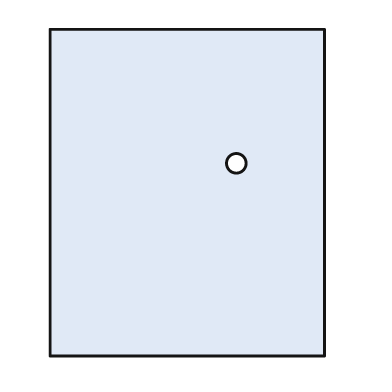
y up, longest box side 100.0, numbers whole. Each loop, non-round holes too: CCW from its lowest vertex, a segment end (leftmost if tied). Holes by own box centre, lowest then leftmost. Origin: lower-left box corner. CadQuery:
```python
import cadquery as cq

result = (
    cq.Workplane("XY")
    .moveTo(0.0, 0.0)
    .lineTo(84.0, 0.0)
    .lineTo(84.0, 100.0)
    .lineTo(0.0, 100.0)
    .close()
    .moveTo(57.0, 59.0)
    .circle(3.0)
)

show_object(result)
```